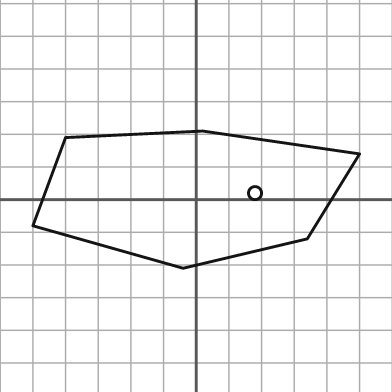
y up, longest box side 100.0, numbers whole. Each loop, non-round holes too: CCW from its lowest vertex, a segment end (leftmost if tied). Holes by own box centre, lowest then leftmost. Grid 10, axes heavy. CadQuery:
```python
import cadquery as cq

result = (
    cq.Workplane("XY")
    .moveTo(-4.0, -21.0)
    .lineTo(34.0, -12.0)
    .lineTo(50.0, 14.0)
    .lineTo(2.0, 21.0)
    .lineTo(-40.0, 19.0)
    .lineTo(-50.0, -8.0)
    .close()
    .moveTo(18.0, 2.0)
    .circle(2.0)
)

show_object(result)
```